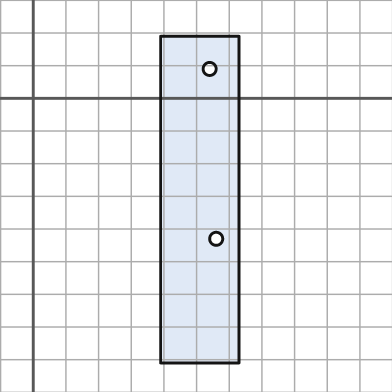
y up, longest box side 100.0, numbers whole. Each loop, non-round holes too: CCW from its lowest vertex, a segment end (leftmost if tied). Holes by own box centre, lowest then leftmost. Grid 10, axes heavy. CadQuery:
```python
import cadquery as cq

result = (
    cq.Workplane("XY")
    .moveTo(39.0, -81.0)
    .lineTo(63.0, -81.0)
    .lineTo(63.0, 19.0)
    .lineTo(39.0, 19.0)
    .close()
    .moveTo(56.0, -43.0)
    .circle(2.0)
    .moveTo(54.0, 9.0)
    .circle(2.0)
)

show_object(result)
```